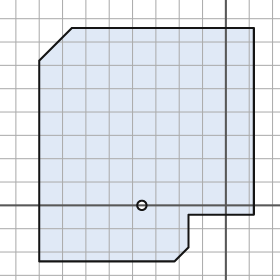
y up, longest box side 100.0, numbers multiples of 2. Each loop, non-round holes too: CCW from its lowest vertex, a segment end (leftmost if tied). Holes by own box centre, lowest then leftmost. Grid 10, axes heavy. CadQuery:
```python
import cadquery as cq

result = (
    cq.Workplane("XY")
    .moveTo(-80.0, -24.0)
    .lineTo(-22.0, -24.0)
    .lineTo(-16.0, -18.0)
    .lineTo(-16.0, -4.0)
    .lineTo(12.0, -4.0)
    .lineTo(12.0, 76.0)
    .lineTo(-66.0, 76.0)
    .lineTo(-80.0, 62.0)
    .close()
    .moveTo(-36.0, 0.0)
    .circle(2.0)
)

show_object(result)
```